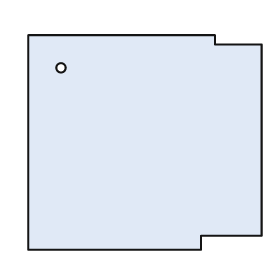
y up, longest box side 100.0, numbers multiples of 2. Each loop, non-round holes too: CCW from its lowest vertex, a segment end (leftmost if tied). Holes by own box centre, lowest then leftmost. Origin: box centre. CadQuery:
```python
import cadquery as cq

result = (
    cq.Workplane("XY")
    .moveTo(-50.0, -46.0)
    .lineTo(24.0, -46.0)
    .lineTo(24.0, -40.0)
    .lineTo(50.0, -40.0)
    .lineTo(50.0, 42.0)
    .lineTo(30.0, 42.0)
    .lineTo(30.0, 46.0)
    .lineTo(-50.0, 46.0)
    .close()
    .moveTo(-36.0, 32.0)
    .circle(2.0)
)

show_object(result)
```